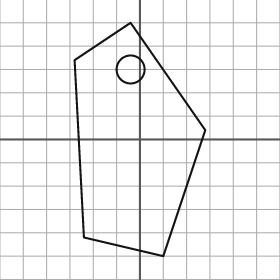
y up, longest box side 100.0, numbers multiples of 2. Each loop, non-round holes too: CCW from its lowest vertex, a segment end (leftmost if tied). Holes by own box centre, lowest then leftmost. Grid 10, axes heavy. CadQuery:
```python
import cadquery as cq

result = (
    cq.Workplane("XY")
    .moveTo(10.0, -50.0)
    .lineTo(28.0, 4.0)
    .lineTo(-4.0, 50.0)
    .lineTo(-28.0, 34.0)
    .lineTo(-24.0, -42.0)
    .close()
    .moveTo(-4.0, 30.0)
    .circle(6.0)
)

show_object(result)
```